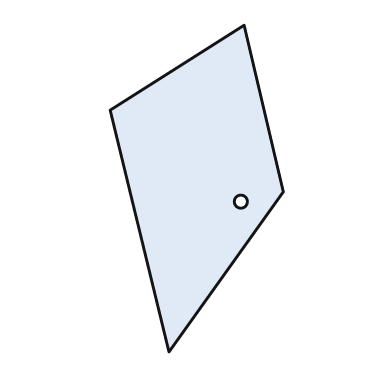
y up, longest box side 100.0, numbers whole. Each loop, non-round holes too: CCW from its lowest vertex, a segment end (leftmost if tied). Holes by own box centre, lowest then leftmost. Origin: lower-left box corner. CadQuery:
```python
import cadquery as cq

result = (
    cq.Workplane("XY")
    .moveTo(18.0, 0.0)
    .lineTo(53.0, 49.0)
    .lineTo(41.0, 100.0)
    .lineTo(0.0, 74.0)
    .close()
    .moveTo(40.0, 46.0)
    .circle(2.0)
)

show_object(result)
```